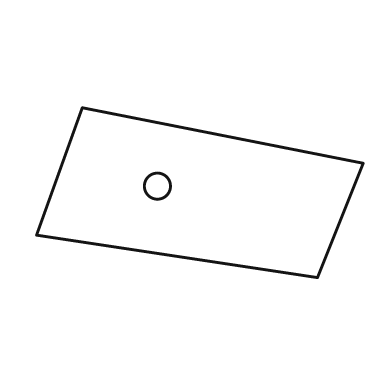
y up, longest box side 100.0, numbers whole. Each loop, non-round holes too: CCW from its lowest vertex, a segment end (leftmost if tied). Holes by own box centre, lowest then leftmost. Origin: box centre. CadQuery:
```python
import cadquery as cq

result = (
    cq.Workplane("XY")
    .moveTo(36.0, -26.0)
    .lineTo(50.0, 9.0)
    .lineTo(-36.0, 26.0)
    .lineTo(-50.0, -13.0)
    .close()
    .moveTo(-13.0, 2.0)
    .circle(4.0)
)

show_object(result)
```